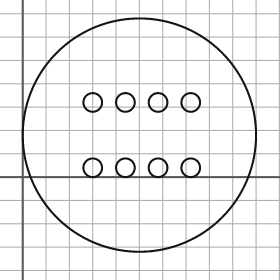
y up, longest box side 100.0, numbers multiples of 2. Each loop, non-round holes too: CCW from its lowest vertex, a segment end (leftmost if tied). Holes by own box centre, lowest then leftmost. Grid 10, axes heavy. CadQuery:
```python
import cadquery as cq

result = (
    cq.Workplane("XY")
    .moveTo(50.0, 18.0)
    .circle(50.0)
    .moveTo(30.0, 4.0)
    .circle(4.0)
    .moveTo(44.0, 4.0)
    .circle(4.0)
    .moveTo(58.0, 4.0)
    .circle(4.0)
    .moveTo(72.0, 4.0)
    .circle(4.0)
    .moveTo(30.0, 32.0)
    .circle(4.0)
    .moveTo(44.0, 32.0)
    .circle(4.0)
    .moveTo(58.0, 32.0)
    .circle(4.0)
    .moveTo(72.0, 32.0)
    .circle(4.0)
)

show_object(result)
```